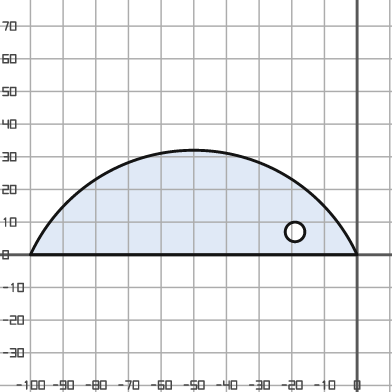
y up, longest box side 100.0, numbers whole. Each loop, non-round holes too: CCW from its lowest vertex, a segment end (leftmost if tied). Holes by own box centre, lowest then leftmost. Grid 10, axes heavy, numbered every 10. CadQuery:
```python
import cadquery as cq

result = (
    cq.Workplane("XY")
    .moveTo(-100.0, 0.0)
    .lineTo(0.0, 0.0)
    .threePointArc((-50.0, 32.0), (-100.0, 0.0))
    .close()
    .moveTo(-19.0, 7.0)
    .circle(3.0)
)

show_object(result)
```